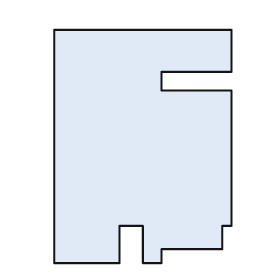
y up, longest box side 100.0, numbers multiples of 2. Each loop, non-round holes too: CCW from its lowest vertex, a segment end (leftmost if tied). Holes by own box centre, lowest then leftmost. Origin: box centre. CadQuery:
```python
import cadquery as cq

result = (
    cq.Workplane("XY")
    .moveTo(-38.0, -50.0)
    .lineTo(-10.0, -50.0)
    .lineTo(-10.0, -34.0)
    .lineTo(0.0, -34.0)
    .lineTo(0.0, -50.0)
    .lineTo(8.0, -50.0)
    .lineTo(8.0, -44.0)
    .lineTo(34.0, -44.0)
    .lineTo(34.0, -34.0)
    .lineTo(38.0, -34.0)
    .lineTo(38.0, 24.0)
    .lineTo(8.0, 24.0)
    .lineTo(8.0, 32.0)
    .lineTo(38.0, 32.0)
    .lineTo(38.0, 50.0)
    .lineTo(-38.0, 50.0)
    .close()
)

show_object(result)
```